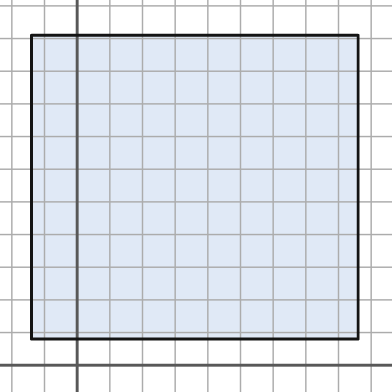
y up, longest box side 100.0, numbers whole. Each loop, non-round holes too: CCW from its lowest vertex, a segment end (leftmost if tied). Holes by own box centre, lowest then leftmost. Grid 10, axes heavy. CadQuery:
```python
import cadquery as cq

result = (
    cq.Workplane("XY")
    .moveTo(-14.0, 8.0)
    .lineTo(86.0, 8.0)
    .lineTo(86.0, 101.0)
    .lineTo(-14.0, 101.0)
    .close()
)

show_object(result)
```